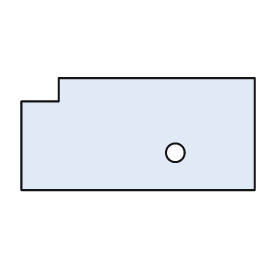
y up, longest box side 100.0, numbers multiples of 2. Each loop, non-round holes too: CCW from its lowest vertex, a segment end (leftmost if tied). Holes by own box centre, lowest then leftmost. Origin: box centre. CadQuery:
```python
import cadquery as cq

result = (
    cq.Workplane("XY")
    .moveTo(-50.0, -24.0)
    .lineTo(50.0, -24.0)
    .lineTo(50.0, 24.0)
    .lineTo(-34.0, 24.0)
    .lineTo(-34.0, 14.0)
    .lineTo(-50.0, 14.0)
    .close()
    .moveTo(16.0, -8.0)
    .circle(4.0)
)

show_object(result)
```